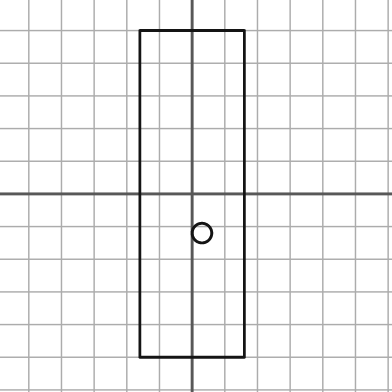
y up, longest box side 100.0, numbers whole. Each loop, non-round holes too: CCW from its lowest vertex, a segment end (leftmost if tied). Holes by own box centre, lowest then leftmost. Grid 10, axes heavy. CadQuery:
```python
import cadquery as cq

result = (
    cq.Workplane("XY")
    .moveTo(-16.0, -50.0)
    .lineTo(16.0, -50.0)
    .lineTo(16.0, 50.0)
    .lineTo(-16.0, 50.0)
    .close()
    .moveTo(3.0, -12.0)
    .circle(3.0)
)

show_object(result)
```